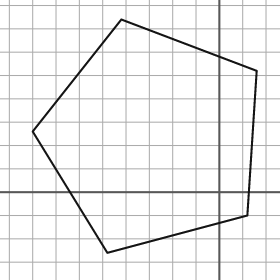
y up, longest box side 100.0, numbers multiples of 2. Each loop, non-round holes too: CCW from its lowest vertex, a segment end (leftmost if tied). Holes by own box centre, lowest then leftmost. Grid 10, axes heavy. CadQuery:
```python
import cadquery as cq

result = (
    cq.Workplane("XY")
    .moveTo(-48.0, -26.0)
    .lineTo(12.0, -10.0)
    .lineTo(16.0, 52.0)
    .lineTo(-42.0, 74.0)
    .lineTo(-80.0, 26.0)
    .close()
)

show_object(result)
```